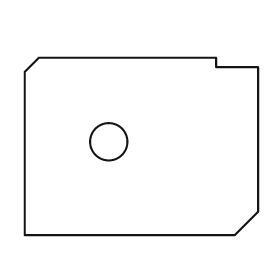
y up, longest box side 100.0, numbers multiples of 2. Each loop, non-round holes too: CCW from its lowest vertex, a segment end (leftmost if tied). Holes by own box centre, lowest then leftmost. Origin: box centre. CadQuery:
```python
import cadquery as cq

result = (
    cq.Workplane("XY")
    .moveTo(-50.0, -38.0)
    .lineTo(40.0, -38.0)
    .lineTo(50.0, -28.0)
    .lineTo(50.0, 34.0)
    .lineTo(32.0, 34.0)
    .lineTo(32.0, 38.0)
    .lineTo(-44.0, 38.0)
    .lineTo(-50.0, 32.0)
    .close()
    .moveTo(-14.0, 2.0)
    .circle(8.0)
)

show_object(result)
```